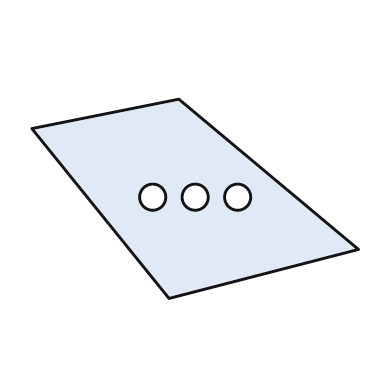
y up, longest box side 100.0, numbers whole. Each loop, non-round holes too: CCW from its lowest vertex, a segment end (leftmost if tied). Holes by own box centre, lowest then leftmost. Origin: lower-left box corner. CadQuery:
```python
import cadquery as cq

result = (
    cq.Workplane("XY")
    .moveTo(42.0, 0.0)
    .lineTo(100.0, 15.0)
    .lineTo(45.0, 61.0)
    .lineTo(0.0, 52.0)
    .close()
    .moveTo(37.0, 31.0)
    .circle(4.0)
    .moveTo(50.0, 31.0)
    .circle(4.0)
    .moveTo(63.0, 31.0)
    .circle(4.0)
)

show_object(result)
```